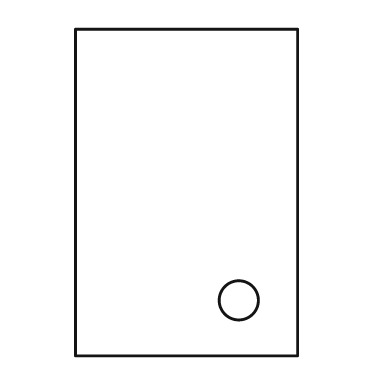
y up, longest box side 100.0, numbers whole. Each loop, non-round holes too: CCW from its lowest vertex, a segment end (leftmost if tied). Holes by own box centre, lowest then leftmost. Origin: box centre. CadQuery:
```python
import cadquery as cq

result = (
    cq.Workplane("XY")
    .moveTo(-34.0, -50.0)
    .lineTo(34.0, -50.0)
    .lineTo(34.0, 50.0)
    .lineTo(-34.0, 50.0)
    .close()
    .moveTo(16.0, -33.0)
    .circle(6.0)
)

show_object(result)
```